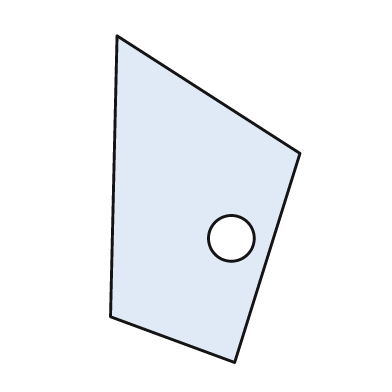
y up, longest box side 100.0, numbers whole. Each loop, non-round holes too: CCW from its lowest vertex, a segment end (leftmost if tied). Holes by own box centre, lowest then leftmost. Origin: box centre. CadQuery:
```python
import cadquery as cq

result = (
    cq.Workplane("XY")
    .moveTo(9.0, -50.0)
    .lineTo(29.0, 14.0)
    .lineTo(-27.0, 50.0)
    .lineTo(-29.0, -36.0)
    .close()
    .moveTo(8.0, -12.0)
    .circle(7.0)
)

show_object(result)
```